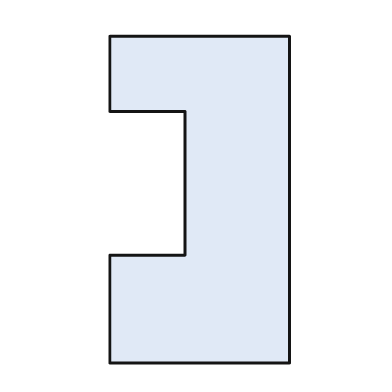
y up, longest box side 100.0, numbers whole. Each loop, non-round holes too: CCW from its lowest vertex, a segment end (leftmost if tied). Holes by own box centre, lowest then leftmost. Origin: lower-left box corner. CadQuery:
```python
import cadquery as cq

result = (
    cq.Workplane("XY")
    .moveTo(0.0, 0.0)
    .lineTo(55.0, 0.0)
    .lineTo(55.0, 100.0)
    .lineTo(0.0, 100.0)
    .lineTo(0.0, 77.0)
    .lineTo(23.0, 77.0)
    .lineTo(23.0, 33.0)
    .lineTo(0.0, 33.0)
    .close()
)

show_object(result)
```